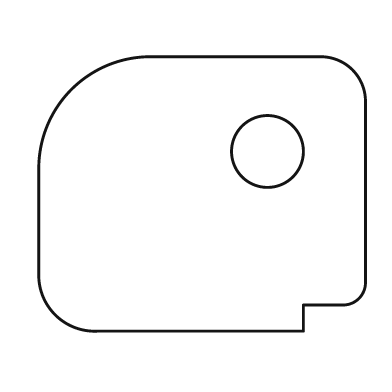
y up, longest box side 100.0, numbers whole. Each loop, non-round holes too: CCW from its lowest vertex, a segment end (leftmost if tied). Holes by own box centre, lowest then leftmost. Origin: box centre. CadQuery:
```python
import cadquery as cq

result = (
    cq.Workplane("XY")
    .moveTo(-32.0, -42.0)
    .lineTo(31.0, -42.0)
    .lineTo(31.0, -34.0)
    .lineTo(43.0, -34.0)
    .threePointArc((48.0, -32.0), (50.0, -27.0))
    .lineTo(50.0, 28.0)
    .threePointArc((46.0, 38.0), (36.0, 42.0))
    .lineTo(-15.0, 42.0)
    .threePointArc((-40.0, 32.0), (-50.0, 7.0))
    .lineTo(-50.0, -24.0)
    .threePointArc((-45.0, -37.0), (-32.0, -42.0))
    .close()
    .moveTo(20.0, 13.0)
    .circle(11.0)
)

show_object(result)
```